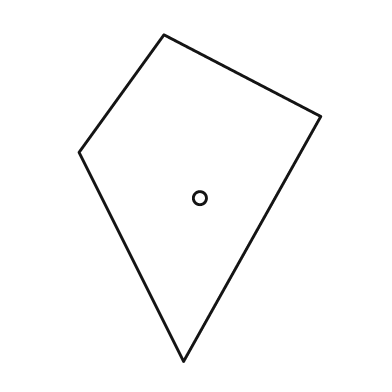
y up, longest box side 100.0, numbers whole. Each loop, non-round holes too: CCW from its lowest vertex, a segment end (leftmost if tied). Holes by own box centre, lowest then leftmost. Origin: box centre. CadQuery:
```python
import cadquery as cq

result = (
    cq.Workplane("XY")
    .moveTo(-5.0, -50.0)
    .lineTo(37.0, 25.0)
    .lineTo(-11.0, 50.0)
    .lineTo(-37.0, 14.0)
    .close()
    .moveTo(0.0, 0.0)
    .circle(2.0)
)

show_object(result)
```